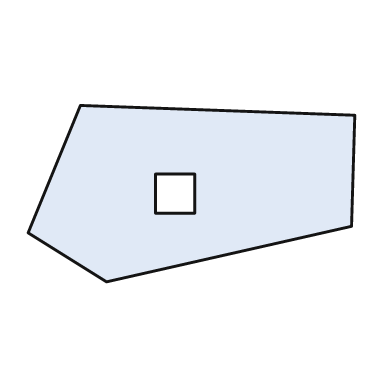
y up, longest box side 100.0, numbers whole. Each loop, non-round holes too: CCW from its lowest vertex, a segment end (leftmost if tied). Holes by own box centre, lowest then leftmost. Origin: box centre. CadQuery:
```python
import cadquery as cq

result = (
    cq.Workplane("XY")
    .moveTo(-26.0, -27.0)
    .lineTo(49.0, -10.0)
    .lineTo(50.0, 24.0)
    .lineTo(-34.0, 27.0)
    .lineTo(-50.0, -12.0)
    .close()
    .moveTo(-11.0, -6.0)
    .lineTo(1.0, -6.0)
    .lineTo(1.0, 6.0)
    .lineTo(-11.0, 6.0)
    .close()
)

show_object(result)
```